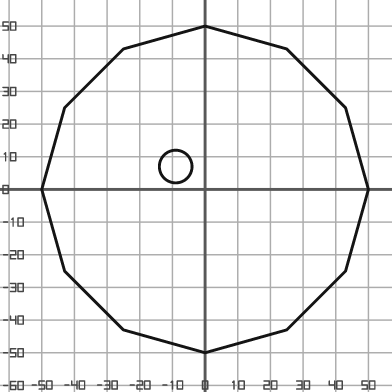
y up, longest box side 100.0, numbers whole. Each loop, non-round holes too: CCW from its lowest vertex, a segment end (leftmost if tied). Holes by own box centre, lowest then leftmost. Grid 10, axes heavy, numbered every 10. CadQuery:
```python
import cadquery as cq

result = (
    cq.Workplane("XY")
    .moveTo(0.0, -50.0)
    .lineTo(25.0, -43.0)
    .lineTo(43.0, -25.0)
    .lineTo(50.0, 0.0)
    .lineTo(43.0, 25.0)
    .lineTo(25.0, 43.0)
    .lineTo(0.0, 50.0)
    .lineTo(-25.0, 43.0)
    .lineTo(-43.0, 25.0)
    .lineTo(-50.0, 0.0)
    .lineTo(-43.0, -25.0)
    .lineTo(-25.0, -43.0)
    .close()
    .moveTo(-9.0, 7.0)
    .circle(5.0)
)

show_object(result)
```